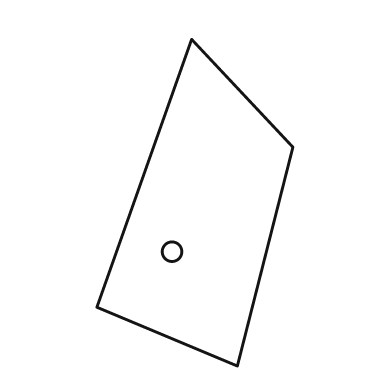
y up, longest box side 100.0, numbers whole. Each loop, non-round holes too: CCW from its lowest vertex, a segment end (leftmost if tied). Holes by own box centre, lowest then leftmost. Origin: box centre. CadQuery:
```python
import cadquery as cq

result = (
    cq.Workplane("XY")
    .moveTo(13.0, -50.0)
    .lineTo(30.0, 17.0)
    .lineTo(-1.0, 50.0)
    .lineTo(-30.0, -32.0)
    .close()
    .moveTo(-7.0, -15.0)
    .circle(3.0)
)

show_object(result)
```